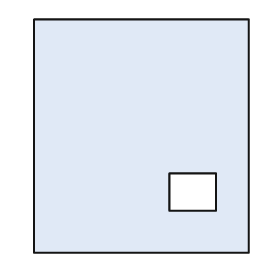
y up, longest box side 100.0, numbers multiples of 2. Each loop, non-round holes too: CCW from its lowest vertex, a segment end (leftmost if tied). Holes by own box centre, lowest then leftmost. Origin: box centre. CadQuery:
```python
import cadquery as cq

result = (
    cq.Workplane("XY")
    .moveTo(-46.0, -50.0)
    .lineTo(46.0, -50.0)
    .lineTo(46.0, 50.0)
    .lineTo(-46.0, 50.0)
    .close()
    .moveTo(12.0, -32.0)
    .lineTo(32.0, -32.0)
    .lineTo(32.0, -16.0)
    .lineTo(12.0, -16.0)
    .close()
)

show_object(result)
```